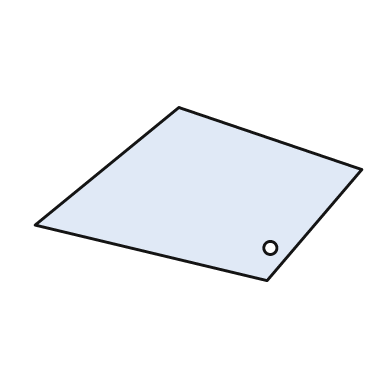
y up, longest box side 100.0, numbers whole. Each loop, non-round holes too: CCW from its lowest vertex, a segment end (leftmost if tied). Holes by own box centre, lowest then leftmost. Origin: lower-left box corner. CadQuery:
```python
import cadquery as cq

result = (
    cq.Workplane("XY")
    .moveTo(71.0, 0.0)
    .lineTo(100.0, 34.0)
    .lineTo(44.0, 53.0)
    .lineTo(0.0, 17.0)
    .close()
    .moveTo(72.0, 10.0)
    .circle(2.0)
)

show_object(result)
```